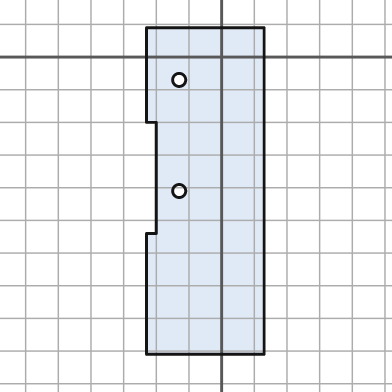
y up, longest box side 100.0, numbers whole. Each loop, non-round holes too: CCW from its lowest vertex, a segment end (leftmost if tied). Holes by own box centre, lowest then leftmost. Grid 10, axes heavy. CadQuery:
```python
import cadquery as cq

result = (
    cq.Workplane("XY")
    .moveTo(-23.0, -91.0)
    .lineTo(13.0, -91.0)
    .lineTo(13.0, 9.0)
    .lineTo(-23.0, 9.0)
    .lineTo(-23.0, -20.0)
    .lineTo(-20.0, -20.0)
    .lineTo(-20.0, -54.0)
    .lineTo(-23.0, -54.0)
    .close()
    .moveTo(-13.0, -41.0)
    .circle(2.0)
    .moveTo(-13.0, -7.0)
    .circle(2.0)
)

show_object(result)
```